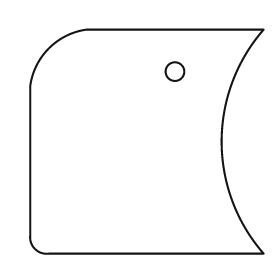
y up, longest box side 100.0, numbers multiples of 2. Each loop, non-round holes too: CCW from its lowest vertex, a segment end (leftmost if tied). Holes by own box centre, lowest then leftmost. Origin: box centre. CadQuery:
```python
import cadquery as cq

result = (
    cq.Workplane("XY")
    .moveTo(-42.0, -48.0)
    .lineTo(50.0, -48.0)
    .threePointArc((32.0, 0.0), (50.0, 48.0))
    .lineTo(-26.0, 48.0)
    .threePointArc((-42.0, 40.0), (-50.0, 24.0))
    .lineTo(-50.0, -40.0)
    .threePointArc((-48.0, -46.0), (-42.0, -48.0))
    .close()
    .moveTo(12.0, 30.0)
    .circle(4.0)
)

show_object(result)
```